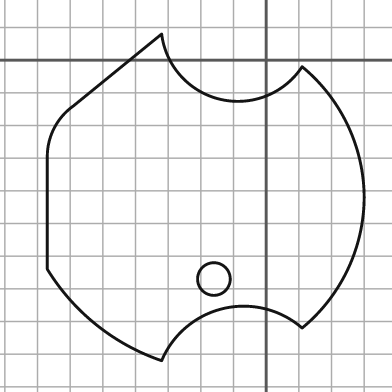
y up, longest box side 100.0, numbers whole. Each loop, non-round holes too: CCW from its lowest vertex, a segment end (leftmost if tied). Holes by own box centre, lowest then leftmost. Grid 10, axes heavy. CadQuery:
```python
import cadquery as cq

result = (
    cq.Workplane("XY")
    .moveTo(-32.0, -92.0)
    .threePointArc((-13.0, -76.0), (11.0, -82.0))
    .threePointArc((25.0, -64.0), (30.0, -42.0))
    .threePointArc((25.0, -20.0), (11.0, -2.0))
    .threePointArc((-14.0, -12.0), (-32.0, 8.0))
    .lineTo(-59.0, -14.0)
    .threePointArc((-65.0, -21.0), (-67.0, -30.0))
    .lineTo(-67.0, -64.0)
    .threePointArc((-52.0, -81.0), (-32.0, -92.0))
    .close()
    .moveTo(-16.0, -67.0)
    .circle(5.0)
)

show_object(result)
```